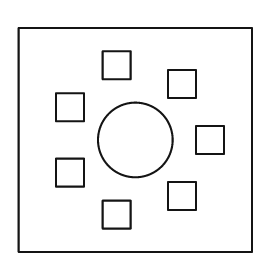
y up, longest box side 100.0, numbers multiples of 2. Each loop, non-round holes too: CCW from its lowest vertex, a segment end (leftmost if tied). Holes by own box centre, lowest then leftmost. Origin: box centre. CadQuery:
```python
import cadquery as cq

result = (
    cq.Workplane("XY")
    .moveTo(-50.0, -48.0)
    .lineTo(50.0, -48.0)
    .lineTo(50.0, 48.0)
    .lineTo(-50.0, 48.0)
    .close()
    .moveTo(-14.0, -38.0)
    .lineTo(-2.0, -38.0)
    .lineTo(-2.0, -26.0)
    .lineTo(-14.0, -26.0)
    .close()
    .moveTo(14.0, -30.0)
    .lineTo(26.0, -30.0)
    .lineTo(26.0, -18.0)
    .lineTo(14.0, -18.0)
    .close()
    .moveTo(-34.0, -20.0)
    .lineTo(-22.0, -20.0)
    .lineTo(-22.0, -8.0)
    .lineTo(-34.0, -8.0)
    .close()
    .moveTo(0.0, 0.0)
    .circle(16.0)
    .moveTo(26.0, -6.0)
    .lineTo(38.0, -6.0)
    .lineTo(38.0, 6.0)
    .lineTo(26.0, 6.0)
    .close()
    .moveTo(-34.0, 8.0)
    .lineTo(-22.0, 8.0)
    .lineTo(-22.0, 20.0)
    .lineTo(-34.0, 20.0)
    .close()
    .moveTo(14.0, 18.0)
    .lineTo(26.0, 18.0)
    .lineTo(26.0, 30.0)
    .lineTo(14.0, 30.0)
    .close()
    .moveTo(-14.0, 26.0)
    .lineTo(-2.0, 26.0)
    .lineTo(-2.0, 38.0)
    .lineTo(-14.0, 38.0)
    .close()
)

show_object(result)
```